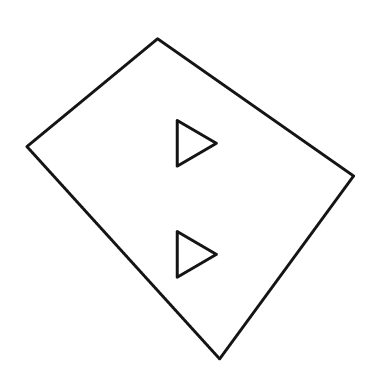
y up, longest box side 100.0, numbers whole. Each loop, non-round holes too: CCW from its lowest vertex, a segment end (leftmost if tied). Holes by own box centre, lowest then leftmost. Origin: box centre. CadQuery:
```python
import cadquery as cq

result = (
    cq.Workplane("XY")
    .moveTo(9.0, -49.0)
    .lineTo(50.0, 7.0)
    .lineTo(-10.0, 49.0)
    .lineTo(-50.0, 16.0)
    .close()
    .moveTo(-4.0, -24.0)
    .lineTo(8.0, -17.0)
    .lineTo(-4.0, -10.0)
    .close()
    .moveTo(-4.0, 10.0)
    .lineTo(8.0, 17.0)
    .lineTo(-4.0, 24.0)
    .close()
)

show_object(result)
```